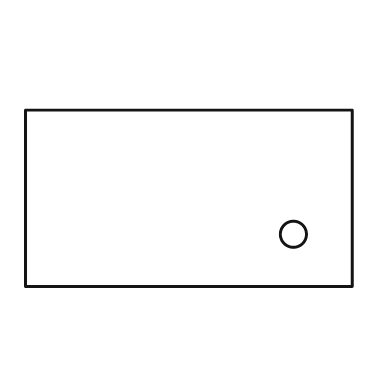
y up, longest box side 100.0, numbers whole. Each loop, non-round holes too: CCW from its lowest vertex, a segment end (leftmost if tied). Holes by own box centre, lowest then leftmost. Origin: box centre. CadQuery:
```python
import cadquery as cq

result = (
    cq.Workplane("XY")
    .moveTo(-50.0, -27.0)
    .lineTo(50.0, -27.0)
    .lineTo(50.0, 27.0)
    .lineTo(-50.0, 27.0)
    .close()
    .moveTo(32.0, -11.0)
    .circle(4.0)
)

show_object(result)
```